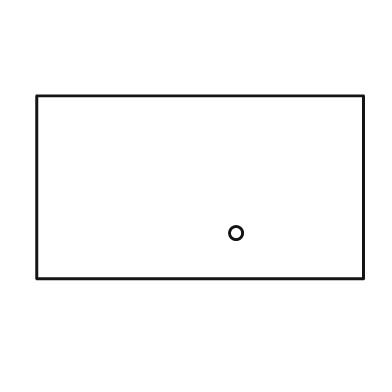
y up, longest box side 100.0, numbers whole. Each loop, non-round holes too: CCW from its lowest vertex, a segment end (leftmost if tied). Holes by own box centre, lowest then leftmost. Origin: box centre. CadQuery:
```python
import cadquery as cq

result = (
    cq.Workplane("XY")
    .moveTo(-50.0, -28.0)
    .lineTo(50.0, -28.0)
    .lineTo(50.0, 28.0)
    .lineTo(-50.0, 28.0)
    .close()
    .moveTo(11.0, -14.0)
    .circle(2.0)
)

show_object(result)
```